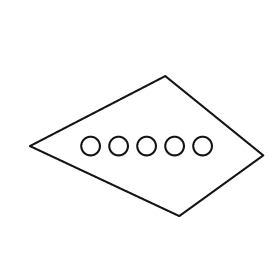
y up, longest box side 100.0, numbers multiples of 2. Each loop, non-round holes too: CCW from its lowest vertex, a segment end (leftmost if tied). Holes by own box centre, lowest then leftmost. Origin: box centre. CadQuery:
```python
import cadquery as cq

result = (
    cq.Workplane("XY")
    .moveTo(14.0, -30.0)
    .lineTo(50.0, -4.0)
    .lineTo(8.0, 30.0)
    .lineTo(-50.0, 0.0)
    .close()
    .moveTo(-24.0, 0.0)
    .circle(4.0)
    .moveTo(-12.0, 0.0)
    .circle(4.0)
    .moveTo(0.0, 0.0)
    .circle(4.0)
    .moveTo(12.0, 0.0)
    .circle(4.0)
    .moveTo(24.0, 0.0)
    .circle(4.0)
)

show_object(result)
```